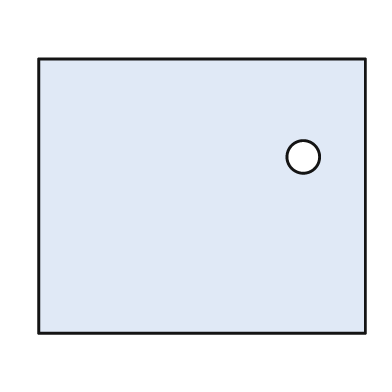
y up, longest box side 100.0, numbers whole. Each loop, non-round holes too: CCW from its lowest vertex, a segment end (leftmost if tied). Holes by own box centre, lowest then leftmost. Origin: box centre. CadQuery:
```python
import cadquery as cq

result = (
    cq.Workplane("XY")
    .moveTo(-50.0, -42.0)
    .lineTo(50.0, -42.0)
    .lineTo(50.0, 42.0)
    .lineTo(-50.0, 42.0)
    .close()
    .moveTo(31.0, 12.0)
    .circle(5.0)
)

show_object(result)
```